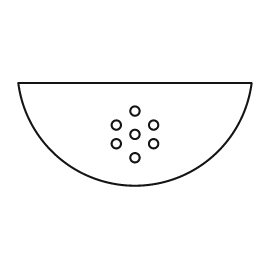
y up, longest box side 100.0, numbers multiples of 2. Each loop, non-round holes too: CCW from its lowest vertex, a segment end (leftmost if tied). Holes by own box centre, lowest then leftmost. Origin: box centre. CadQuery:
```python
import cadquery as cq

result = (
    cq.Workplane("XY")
    .moveTo(-50.0, 22.0)
    .threePointArc((0.0, -22.0), (50.0, 22.0))
    .close()
    .moveTo(0.0, -10.0)
    .circle(2.0)
    .moveTo(-8.0, -4.0)
    .circle(2.0)
    .moveTo(8.0, -4.0)
    .circle(2.0)
    .moveTo(0.0, 0.0)
    .circle(2.0)
    .moveTo(-8.0, 4.0)
    .circle(2.0)
    .moveTo(8.0, 4.0)
    .circle(2.0)
    .moveTo(0.0, 10.0)
    .circle(2.0)
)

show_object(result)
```